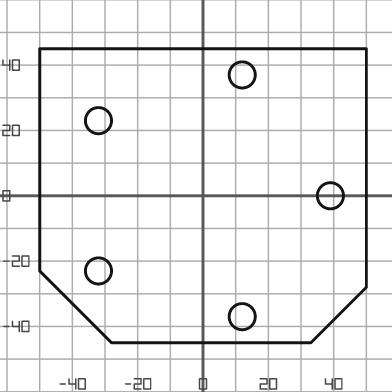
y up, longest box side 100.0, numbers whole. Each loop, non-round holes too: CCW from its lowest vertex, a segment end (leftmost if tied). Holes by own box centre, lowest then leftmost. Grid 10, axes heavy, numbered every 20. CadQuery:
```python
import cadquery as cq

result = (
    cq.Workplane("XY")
    .moveTo(-28.0, -45.0)
    .lineTo(33.0, -45.0)
    .lineTo(50.0, -28.0)
    .lineTo(50.0, 45.0)
    .lineTo(-50.0, 45.0)
    .lineTo(-50.0, -23.0)
    .close()
    .moveTo(12.0, -37.0)
    .circle(4.0)
    .moveTo(-32.0, -23.0)
    .circle(4.0)
    .moveTo(39.0, 0.0)
    .circle(4.0)
    .moveTo(-32.0, 23.0)
    .circle(4.0)
    .moveTo(12.0, 37.0)
    .circle(4.0)
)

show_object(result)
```